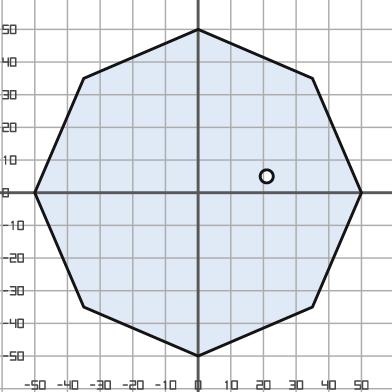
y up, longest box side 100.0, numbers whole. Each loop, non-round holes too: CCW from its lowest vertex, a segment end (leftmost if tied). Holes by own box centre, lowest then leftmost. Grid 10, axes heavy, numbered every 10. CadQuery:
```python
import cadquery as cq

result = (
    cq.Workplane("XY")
    .moveTo(0.0, -50.0)
    .lineTo(35.0, -35.0)
    .lineTo(50.0, 0.0)
    .lineTo(35.0, 35.0)
    .lineTo(0.0, 50.0)
    .lineTo(-35.0, 35.0)
    .lineTo(-50.0, 0.0)
    .lineTo(-35.0, -35.0)
    .close()
    .moveTo(21.0, 5.0)
    .circle(2.0)
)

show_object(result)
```